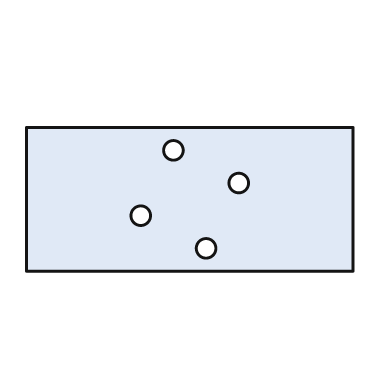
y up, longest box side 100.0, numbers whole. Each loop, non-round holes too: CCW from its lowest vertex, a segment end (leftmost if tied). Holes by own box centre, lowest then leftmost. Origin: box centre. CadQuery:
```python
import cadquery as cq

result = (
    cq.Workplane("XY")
    .moveTo(-50.0, -22.0)
    .lineTo(50.0, -22.0)
    .lineTo(50.0, 22.0)
    .lineTo(-50.0, 22.0)
    .close()
    .moveTo(5.0, -15.0)
    .circle(3.0)
    .moveTo(-15.0, -5.0)
    .circle(3.0)
    .moveTo(15.0, 5.0)
    .circle(3.0)
    .moveTo(-5.0, 15.0)
    .circle(3.0)
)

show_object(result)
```